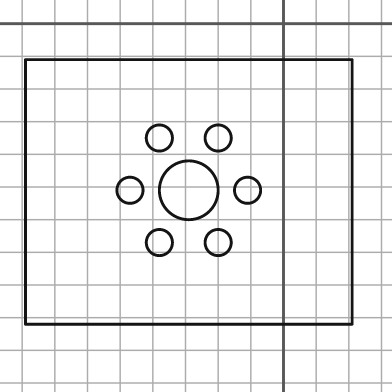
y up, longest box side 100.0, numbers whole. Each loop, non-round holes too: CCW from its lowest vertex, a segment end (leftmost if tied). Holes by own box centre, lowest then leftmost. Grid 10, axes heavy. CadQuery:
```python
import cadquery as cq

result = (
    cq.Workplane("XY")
    .moveTo(-79.0, -92.0)
    .lineTo(21.0, -92.0)
    .lineTo(21.0, -11.0)
    .lineTo(-79.0, -11.0)
    .close()
    .moveTo(-38.0, -67.0)
    .circle(4.0)
    .moveTo(-20.0, -67.0)
    .circle(4.0)
    .moveTo(-47.0, -51.0)
    .circle(4.0)
    .moveTo(-29.0, -51.0)
    .circle(9.0)
    .moveTo(-11.0, -51.0)
    .circle(4.0)
    .moveTo(-38.0, -35.0)
    .circle(4.0)
    .moveTo(-20.0, -35.0)
    .circle(4.0)
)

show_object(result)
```